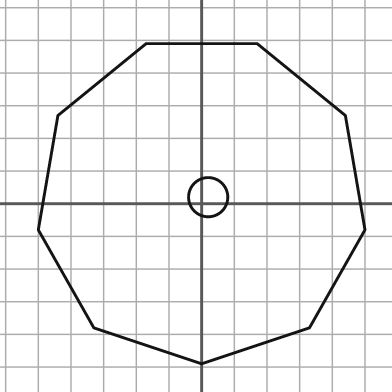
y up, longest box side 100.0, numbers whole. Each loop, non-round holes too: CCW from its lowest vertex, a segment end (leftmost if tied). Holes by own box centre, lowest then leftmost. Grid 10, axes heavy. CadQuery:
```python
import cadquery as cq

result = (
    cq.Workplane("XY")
    .moveTo(0.0, -49.0)
    .lineTo(33.0, -38.0)
    .lineTo(50.0, -8.0)
    .lineTo(44.0, 27.0)
    .lineTo(17.0, 49.0)
    .lineTo(-17.0, 49.0)
    .lineTo(-44.0, 27.0)
    .lineTo(-50.0, -8.0)
    .lineTo(-33.0, -38.0)
    .close()
    .moveTo(2.0, 2.0)
    .circle(6.0)
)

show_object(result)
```